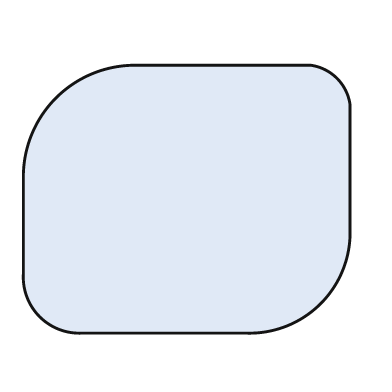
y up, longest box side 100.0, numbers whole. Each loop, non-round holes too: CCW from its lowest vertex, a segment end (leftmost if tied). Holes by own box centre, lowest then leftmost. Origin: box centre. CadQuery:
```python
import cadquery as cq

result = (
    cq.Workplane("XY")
    .moveTo(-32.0, -41.0)
    .lineTo(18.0, -41.0)
    .threePointArc((41.0, -32.0), (50.0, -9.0))
    .lineTo(50.0, 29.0)
    .threePointArc((46.0, 37.0), (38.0, 41.0))
    .lineTo(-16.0, 41.0)
    .threePointArc((-40.0, 31.0), (-50.0, 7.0))
    .lineTo(-50.0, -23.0)
    .threePointArc((-45.0, -36.0), (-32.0, -41.0))
    .close()
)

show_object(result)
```